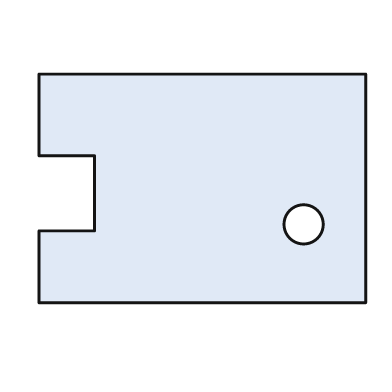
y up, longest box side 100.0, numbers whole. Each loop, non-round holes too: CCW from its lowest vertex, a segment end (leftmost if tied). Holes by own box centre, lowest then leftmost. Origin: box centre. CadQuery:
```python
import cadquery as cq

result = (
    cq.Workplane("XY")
    .moveTo(-50.0, -35.0)
    .lineTo(50.0, -35.0)
    .lineTo(50.0, 35.0)
    .lineTo(-50.0, 35.0)
    .lineTo(-50.0, 10.0)
    .lineTo(-33.0, 10.0)
    .lineTo(-33.0, -13.0)
    .lineTo(-50.0, -13.0)
    .close()
    .moveTo(31.0, -11.0)
    .circle(6.0)
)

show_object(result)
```